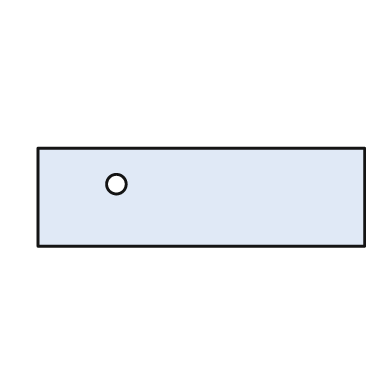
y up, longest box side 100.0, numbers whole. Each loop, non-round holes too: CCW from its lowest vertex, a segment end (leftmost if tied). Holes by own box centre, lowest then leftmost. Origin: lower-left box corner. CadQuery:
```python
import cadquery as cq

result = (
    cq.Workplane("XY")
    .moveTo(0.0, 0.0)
    .lineTo(100.0, 0.0)
    .lineTo(100.0, 30.0)
    .lineTo(0.0, 30.0)
    .close()
    .moveTo(24.0, 19.0)
    .circle(3.0)
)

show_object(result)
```